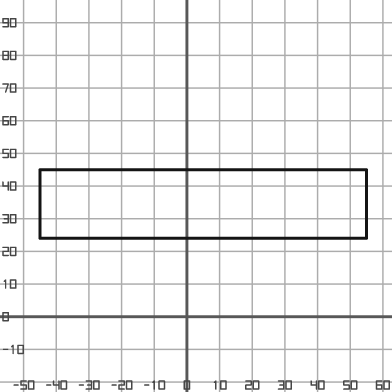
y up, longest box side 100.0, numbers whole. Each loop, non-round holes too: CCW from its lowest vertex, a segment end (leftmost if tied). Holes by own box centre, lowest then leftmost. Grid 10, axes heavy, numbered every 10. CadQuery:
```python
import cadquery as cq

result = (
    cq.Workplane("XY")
    .moveTo(-45.0, 24.0)
    .lineTo(55.0, 24.0)
    .lineTo(55.0, 45.0)
    .lineTo(-45.0, 45.0)
    .close()
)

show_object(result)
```